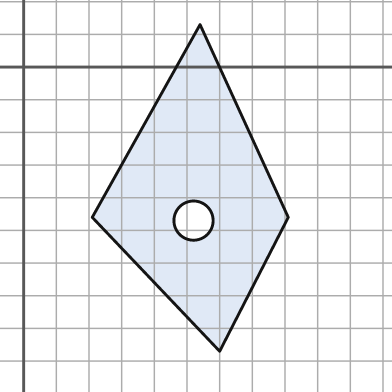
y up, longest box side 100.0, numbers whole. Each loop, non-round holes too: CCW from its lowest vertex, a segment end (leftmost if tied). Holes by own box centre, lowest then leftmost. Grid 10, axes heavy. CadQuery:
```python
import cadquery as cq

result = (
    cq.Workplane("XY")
    .moveTo(60.0, -87.0)
    .lineTo(81.0, -46.0)
    .lineTo(54.0, 13.0)
    .lineTo(21.0, -46.0)
    .close()
    .moveTo(52.0, -47.0)
    .circle(6.0)
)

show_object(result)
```